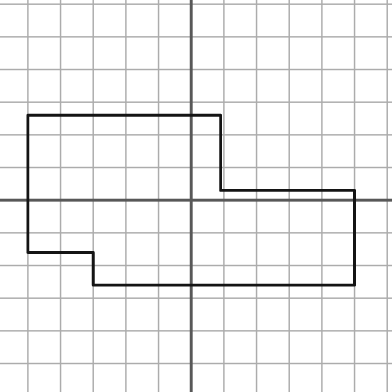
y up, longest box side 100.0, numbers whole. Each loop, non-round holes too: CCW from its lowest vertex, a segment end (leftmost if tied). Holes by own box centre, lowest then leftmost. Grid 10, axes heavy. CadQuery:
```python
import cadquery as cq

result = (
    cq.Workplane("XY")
    .moveTo(-30.0, -26.0)
    .lineTo(50.0, -26.0)
    .lineTo(50.0, 3.0)
    .lineTo(9.0, 3.0)
    .lineTo(9.0, 26.0)
    .lineTo(-50.0, 26.0)
    .lineTo(-50.0, -16.0)
    .lineTo(-30.0, -16.0)
    .close()
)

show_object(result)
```